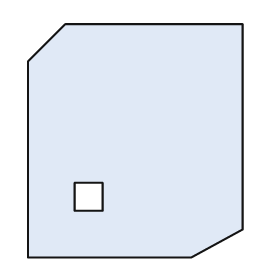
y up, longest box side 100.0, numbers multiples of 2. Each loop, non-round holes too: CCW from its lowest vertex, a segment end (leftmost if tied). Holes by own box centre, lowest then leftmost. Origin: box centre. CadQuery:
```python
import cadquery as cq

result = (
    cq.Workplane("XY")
    .moveTo(-46.0, -50.0)
    .lineTo(24.0, -50.0)
    .lineTo(46.0, -38.0)
    .lineTo(46.0, 50.0)
    .lineTo(-30.0, 50.0)
    .lineTo(-46.0, 34.0)
    .close()
    .moveTo(-26.0, -30.0)
    .lineTo(-14.0, -30.0)
    .lineTo(-14.0, -18.0)
    .lineTo(-26.0, -18.0)
    .close()
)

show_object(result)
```